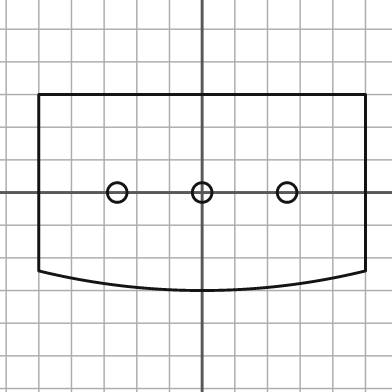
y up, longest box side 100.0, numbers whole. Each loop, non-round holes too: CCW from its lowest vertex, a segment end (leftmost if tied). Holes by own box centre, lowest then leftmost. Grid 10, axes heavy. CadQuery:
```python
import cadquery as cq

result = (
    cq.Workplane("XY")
    .moveTo(-50.0, -24.0)
    .threePointArc((0.0, -30.0), (50.0, -24.0))
    .lineTo(50.0, 30.0)
    .lineTo(-50.0, 30.0)
    .close()
    .moveTo(-26.0, 0.0)
    .circle(3.0)
    .moveTo(0.0, 0.0)
    .circle(3.0)
    .moveTo(26.0, 0.0)
    .circle(3.0)
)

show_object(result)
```